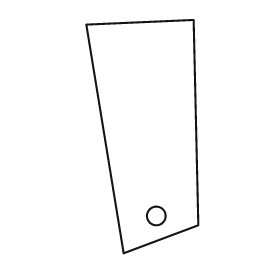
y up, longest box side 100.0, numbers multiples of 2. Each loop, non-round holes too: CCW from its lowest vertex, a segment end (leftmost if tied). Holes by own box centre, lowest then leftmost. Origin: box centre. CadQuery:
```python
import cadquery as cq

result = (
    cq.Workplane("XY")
    .moveTo(-8.0, -50.0)
    .lineTo(24.0, -38.0)
    .lineTo(22.0, 50.0)
    .lineTo(-24.0, 48.0)
    .close()
    .moveTo(6.0, -34.0)
    .circle(4.0)
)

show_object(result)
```